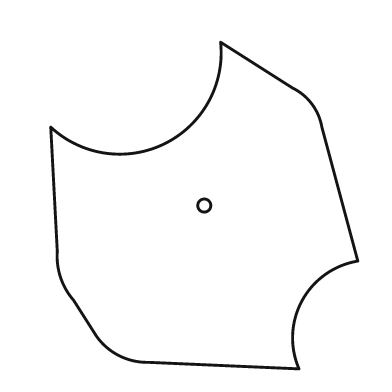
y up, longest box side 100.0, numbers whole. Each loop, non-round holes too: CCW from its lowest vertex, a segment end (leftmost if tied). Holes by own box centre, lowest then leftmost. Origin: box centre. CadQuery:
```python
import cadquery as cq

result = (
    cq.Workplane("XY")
    .moveTo(29.0, -50.0)
    .threePointArc((30.0, -29.0), (47.0, -17.0))
    .lineTo(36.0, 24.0)
    .threePointArc((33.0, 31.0), (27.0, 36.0))
    .lineTo(5.0, 50.0)
    .threePointArc((-12.0, 19.0), (-47.0, 24.0))
    .lineTo(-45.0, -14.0)
    .threePointArc((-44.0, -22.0), (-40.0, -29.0))
    .lineTo(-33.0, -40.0)
    .threePointArc((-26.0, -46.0), (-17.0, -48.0))
    .close()
    .moveTo(0.0, 0.0)
    .circle(2.0)
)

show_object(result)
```